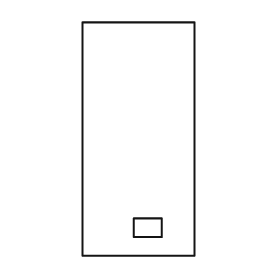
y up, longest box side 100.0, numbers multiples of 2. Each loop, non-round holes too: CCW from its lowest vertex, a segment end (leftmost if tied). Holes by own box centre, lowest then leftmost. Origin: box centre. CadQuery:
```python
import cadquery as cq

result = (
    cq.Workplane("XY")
    .moveTo(-24.0, -50.0)
    .lineTo(24.0, -50.0)
    .lineTo(24.0, 50.0)
    .lineTo(-24.0, 50.0)
    .close()
    .moveTo(-2.0, -42.0)
    .lineTo(10.0, -42.0)
    .lineTo(10.0, -34.0)
    .lineTo(-2.0, -34.0)
    .close()
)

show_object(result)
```